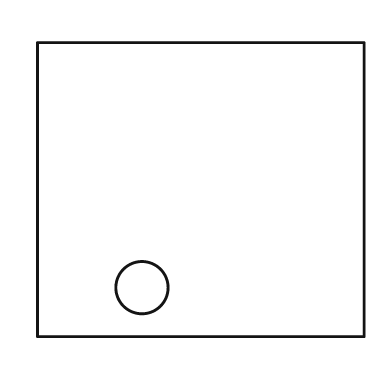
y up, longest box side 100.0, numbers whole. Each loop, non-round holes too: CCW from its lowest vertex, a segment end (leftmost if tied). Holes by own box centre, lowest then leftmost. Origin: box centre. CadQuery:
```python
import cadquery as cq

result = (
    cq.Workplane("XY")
    .moveTo(-50.0, -45.0)
    .lineTo(50.0, -45.0)
    .lineTo(50.0, 45.0)
    .lineTo(-50.0, 45.0)
    .close()
    .moveTo(-18.0, -30.0)
    .circle(8.0)
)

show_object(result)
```